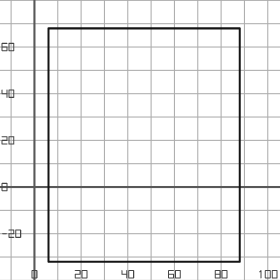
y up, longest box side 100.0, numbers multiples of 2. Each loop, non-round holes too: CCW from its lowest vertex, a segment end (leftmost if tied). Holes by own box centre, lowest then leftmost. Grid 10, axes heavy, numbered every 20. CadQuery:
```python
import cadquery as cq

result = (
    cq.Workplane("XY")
    .moveTo(6.0, -32.0)
    .lineTo(88.0, -32.0)
    .lineTo(88.0, 68.0)
    .lineTo(6.0, 68.0)
    .close()
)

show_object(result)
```